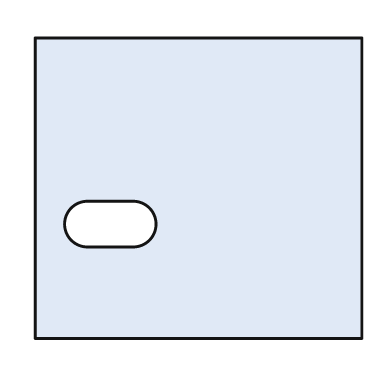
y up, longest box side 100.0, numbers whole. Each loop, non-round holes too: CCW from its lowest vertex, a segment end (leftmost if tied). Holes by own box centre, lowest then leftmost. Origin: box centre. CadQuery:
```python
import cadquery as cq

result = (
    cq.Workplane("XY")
    .moveTo(-50.0, -46.0)
    .lineTo(50.0, -46.0)
    .lineTo(50.0, 46.0)
    .lineTo(-50.0, 46.0)
    .close()
    .moveTo(-34.0, -18.0)
    .lineTo(-20.0, -18.0)
    .threePointArc((-13.0, -11.0), (-20.0, -4.0))
    .lineTo(-34.0, -4.0)
    .threePointArc((-41.0, -11.0), (-34.0, -18.0))
    .close()
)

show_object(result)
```